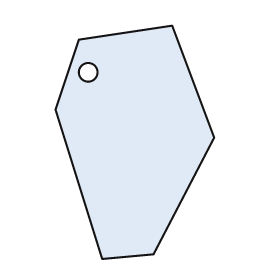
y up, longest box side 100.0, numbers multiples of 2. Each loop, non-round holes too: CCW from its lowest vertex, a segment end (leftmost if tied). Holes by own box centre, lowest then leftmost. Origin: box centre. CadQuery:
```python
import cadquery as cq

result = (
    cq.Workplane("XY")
    .moveTo(-14.0, -50.0)
    .lineTo(8.0, -48.0)
    .lineTo(34.0, 2.0)
    .lineTo(16.0, 50.0)
    .lineTo(-24.0, 44.0)
    .lineTo(-34.0, 14.0)
    .close()
    .moveTo(-20.0, 30.0)
    .circle(4.0)
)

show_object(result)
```